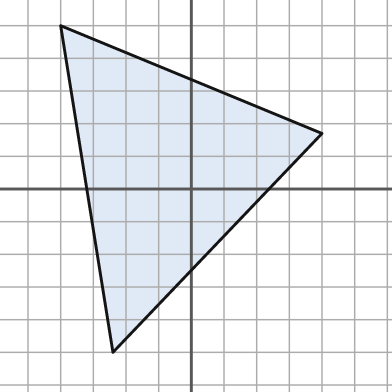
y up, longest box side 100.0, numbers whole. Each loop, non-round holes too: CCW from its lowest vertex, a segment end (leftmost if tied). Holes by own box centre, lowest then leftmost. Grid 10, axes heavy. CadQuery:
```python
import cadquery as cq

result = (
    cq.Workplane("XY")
    .moveTo(-24.0, -50.0)
    .lineTo(40.0, 17.0)
    .lineTo(-40.0, 50.0)
    .close()
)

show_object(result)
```